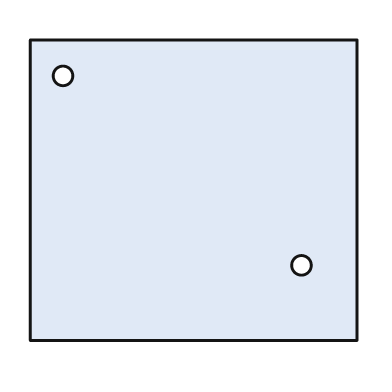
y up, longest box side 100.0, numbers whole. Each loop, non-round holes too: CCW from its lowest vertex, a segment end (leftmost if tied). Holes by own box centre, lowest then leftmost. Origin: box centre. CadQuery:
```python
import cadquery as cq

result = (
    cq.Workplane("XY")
    .moveTo(-50.0, -46.0)
    .lineTo(50.0, -46.0)
    .lineTo(50.0, 46.0)
    .lineTo(-50.0, 46.0)
    .close()
    .moveTo(33.0, -23.0)
    .circle(3.0)
    .moveTo(-40.0, 35.0)
    .circle(3.0)
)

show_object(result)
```